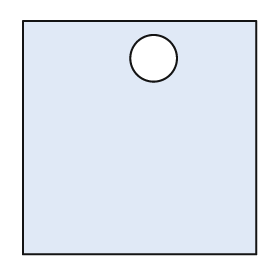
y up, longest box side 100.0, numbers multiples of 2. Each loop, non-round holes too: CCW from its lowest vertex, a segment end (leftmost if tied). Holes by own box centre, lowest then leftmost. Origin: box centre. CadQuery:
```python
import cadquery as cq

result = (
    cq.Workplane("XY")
    .moveTo(-50.0, -50.0)
    .lineTo(50.0, -50.0)
    .lineTo(50.0, 50.0)
    .lineTo(-50.0, 50.0)
    .close()
    .moveTo(6.0, 34.0)
    .circle(10.0)
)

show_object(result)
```